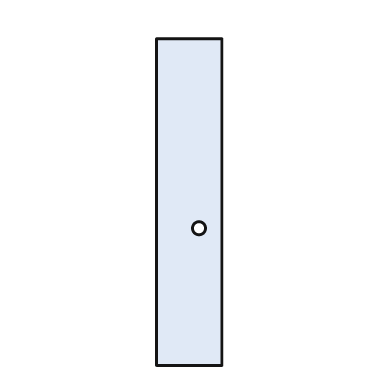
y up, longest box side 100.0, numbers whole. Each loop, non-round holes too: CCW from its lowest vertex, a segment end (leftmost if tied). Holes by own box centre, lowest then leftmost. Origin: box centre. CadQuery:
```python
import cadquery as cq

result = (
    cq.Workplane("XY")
    .moveTo(-10.0, -50.0)
    .lineTo(10.0, -50.0)
    .lineTo(10.0, 50.0)
    .lineTo(-10.0, 50.0)
    .close()
    .moveTo(3.0, -8.0)
    .circle(2.0)
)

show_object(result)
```